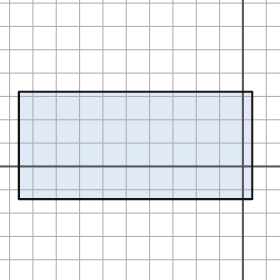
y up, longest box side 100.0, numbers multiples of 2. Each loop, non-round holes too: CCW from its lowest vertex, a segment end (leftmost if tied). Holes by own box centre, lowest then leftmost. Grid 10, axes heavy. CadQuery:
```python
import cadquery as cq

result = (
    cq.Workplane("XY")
    .moveTo(-96.0, -14.0)
    .lineTo(4.0, -14.0)
    .lineTo(4.0, 32.0)
    .lineTo(-96.0, 32.0)
    .close()
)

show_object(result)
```